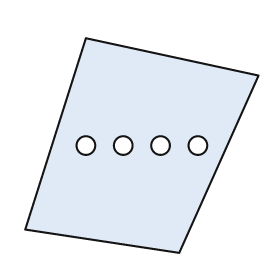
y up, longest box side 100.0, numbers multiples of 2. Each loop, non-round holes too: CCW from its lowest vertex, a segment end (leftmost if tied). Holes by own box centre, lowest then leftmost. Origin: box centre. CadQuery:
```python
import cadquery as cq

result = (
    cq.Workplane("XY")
    .moveTo(16.0, -46.0)
    .lineTo(50.0, 30.0)
    .lineTo(-24.0, 46.0)
    .lineTo(-50.0, -36.0)
    .close()
    .moveTo(-24.0, 0.0)
    .circle(4.0)
    .moveTo(-8.0, 0.0)
    .circle(4.0)
    .moveTo(8.0, 0.0)
    .circle(4.0)
    .moveTo(24.0, 0.0)
    .circle(4.0)
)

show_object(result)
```